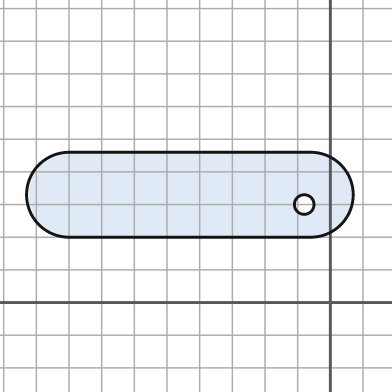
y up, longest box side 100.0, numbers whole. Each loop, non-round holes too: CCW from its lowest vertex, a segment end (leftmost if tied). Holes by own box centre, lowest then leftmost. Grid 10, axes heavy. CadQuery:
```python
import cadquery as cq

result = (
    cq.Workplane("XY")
    .moveTo(-80.0, 20.0)
    .lineTo(-6.0, 20.0)
    .threePointArc((7.0, 33.0), (-6.0, 46.0))
    .lineTo(-80.0, 46.0)
    .threePointArc((-93.0, 33.0), (-80.0, 20.0))
    .close()
    .moveTo(-8.0, 30.0)
    .circle(3.0)
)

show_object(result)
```